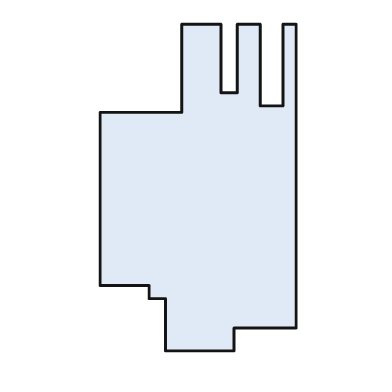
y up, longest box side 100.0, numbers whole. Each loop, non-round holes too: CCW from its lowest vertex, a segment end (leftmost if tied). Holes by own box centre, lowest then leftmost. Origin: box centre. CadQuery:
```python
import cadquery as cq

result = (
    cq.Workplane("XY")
    .moveTo(-10.0, -50.0)
    .lineTo(11.0, -50.0)
    .lineTo(11.0, -43.0)
    .lineTo(30.0, -43.0)
    .lineTo(30.0, 50.0)
    .lineTo(26.0, 50.0)
    .lineTo(26.0, 25.0)
    .lineTo(19.0, 25.0)
    .lineTo(19.0, 50.0)
    .lineTo(12.0, 50.0)
    .lineTo(12.0, 29.0)
    .lineTo(7.0, 29.0)
    .lineTo(7.0, 50.0)
    .lineTo(-5.0, 50.0)
    .lineTo(-5.0, 23.0)
    .lineTo(-30.0, 23.0)
    .lineTo(-30.0, -30.0)
    .lineTo(-15.0, -30.0)
    .lineTo(-15.0, -34.0)
    .lineTo(-10.0, -34.0)
    .close()
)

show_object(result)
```